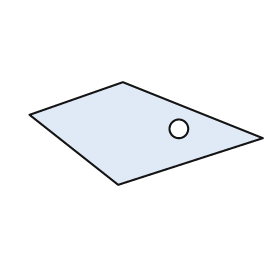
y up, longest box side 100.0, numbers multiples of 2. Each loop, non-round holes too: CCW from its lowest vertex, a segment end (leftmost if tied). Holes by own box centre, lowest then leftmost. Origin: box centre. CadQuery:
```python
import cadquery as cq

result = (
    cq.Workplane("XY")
    .moveTo(-12.0, -22.0)
    .lineTo(50.0, -2.0)
    .lineTo(-10.0, 22.0)
    .lineTo(-50.0, 8.0)
    .close()
    .moveTo(14.0, 2.0)
    .circle(4.0)
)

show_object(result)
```